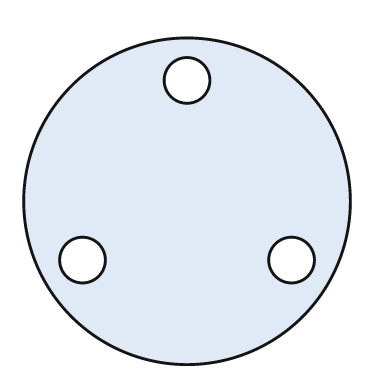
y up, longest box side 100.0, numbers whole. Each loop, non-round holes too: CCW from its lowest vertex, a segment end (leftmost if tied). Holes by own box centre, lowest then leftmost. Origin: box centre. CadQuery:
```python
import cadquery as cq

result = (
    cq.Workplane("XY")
    .moveTo(0.0, 0.0)
    .circle(50.0)
    .moveTo(-32.0, -18.0)
    .circle(7.0)
    .moveTo(32.0, -18.0)
    .circle(7.0)
    .moveTo(0.0, 37.0)
    .circle(7.0)
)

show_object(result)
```